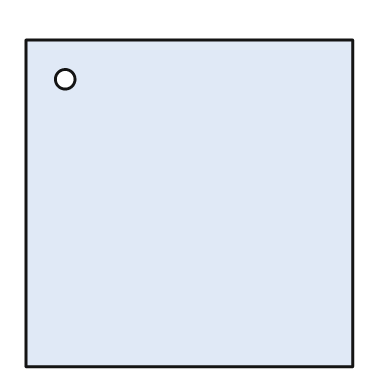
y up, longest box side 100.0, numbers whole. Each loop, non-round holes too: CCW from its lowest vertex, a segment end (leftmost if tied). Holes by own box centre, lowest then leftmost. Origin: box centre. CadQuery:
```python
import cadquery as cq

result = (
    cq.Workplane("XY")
    .moveTo(-50.0, -50.0)
    .lineTo(50.0, -50.0)
    .lineTo(50.0, 50.0)
    .lineTo(-50.0, 50.0)
    .close()
    .moveTo(-38.0, 38.0)
    .circle(3.0)
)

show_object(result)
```